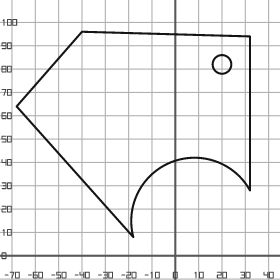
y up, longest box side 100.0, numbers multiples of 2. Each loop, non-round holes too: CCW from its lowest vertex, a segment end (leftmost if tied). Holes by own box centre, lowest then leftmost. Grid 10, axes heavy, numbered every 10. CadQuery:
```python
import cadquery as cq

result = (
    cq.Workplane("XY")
    .moveTo(-18.0, 8.0)
    .threePointArc((-2.0, 40.0), (32.0, 28.0))
    .lineTo(32.0, 94.0)
    .lineTo(-40.0, 96.0)
    .lineTo(-68.0, 64.0)
    .close()
    .moveTo(20.0, 82.0)
    .circle(4.0)
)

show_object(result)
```